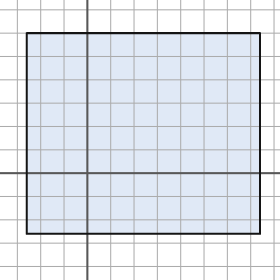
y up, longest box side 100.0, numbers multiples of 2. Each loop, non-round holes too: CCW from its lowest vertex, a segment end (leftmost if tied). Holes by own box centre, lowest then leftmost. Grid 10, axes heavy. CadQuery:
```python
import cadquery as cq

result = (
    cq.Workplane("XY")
    .moveTo(-26.0, -26.0)
    .lineTo(74.0, -26.0)
    .lineTo(74.0, 60.0)
    .lineTo(-26.0, 60.0)
    .close()
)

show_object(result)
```